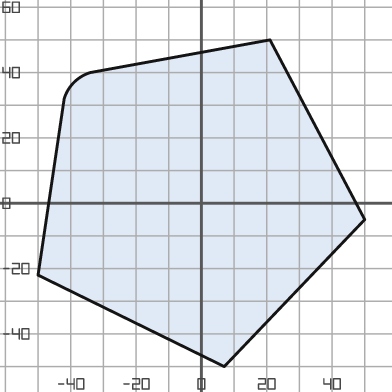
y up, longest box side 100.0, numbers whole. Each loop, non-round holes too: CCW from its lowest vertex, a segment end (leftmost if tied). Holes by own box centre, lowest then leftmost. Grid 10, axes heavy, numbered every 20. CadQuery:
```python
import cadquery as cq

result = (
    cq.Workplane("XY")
    .moveTo(7.0, -50.0)
    .lineTo(50.0, -5.0)
    .lineTo(21.0, 50.0)
    .lineTo(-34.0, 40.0)
    .threePointArc((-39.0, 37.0), (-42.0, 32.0))
    .lineTo(-50.0, -22.0)
    .close()
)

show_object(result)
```